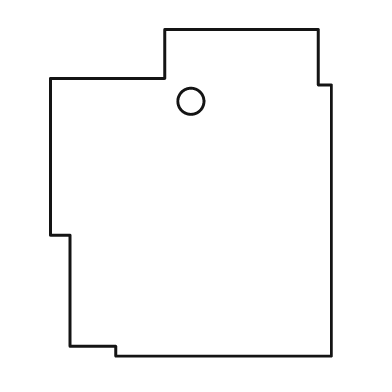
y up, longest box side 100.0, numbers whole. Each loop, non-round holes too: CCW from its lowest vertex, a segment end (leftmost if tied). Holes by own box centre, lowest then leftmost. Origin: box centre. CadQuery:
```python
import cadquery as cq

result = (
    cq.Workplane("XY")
    .moveTo(-23.0, -50.0)
    .lineTo(43.0, -50.0)
    .lineTo(43.0, 33.0)
    .lineTo(39.0, 33.0)
    .lineTo(39.0, 50.0)
    .lineTo(-8.0, 50.0)
    .lineTo(-8.0, 35.0)
    .lineTo(-43.0, 35.0)
    .lineTo(-43.0, -13.0)
    .lineTo(-37.0, -13.0)
    .lineTo(-37.0, -47.0)
    .lineTo(-23.0, -47.0)
    .close()
    .moveTo(0.0, 28.0)
    .circle(4.0)
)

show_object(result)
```